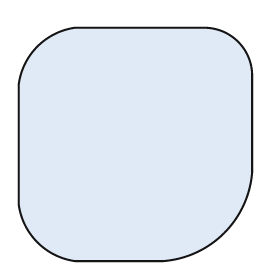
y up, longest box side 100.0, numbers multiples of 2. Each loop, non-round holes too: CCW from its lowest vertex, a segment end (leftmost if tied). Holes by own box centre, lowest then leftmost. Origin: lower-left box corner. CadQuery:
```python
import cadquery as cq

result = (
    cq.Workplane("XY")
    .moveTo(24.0, 0.0)
    .lineTo(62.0, 0.0)
    .threePointArc((88.0, 12.0), (100.0, 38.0))
    .lineTo(100.0, 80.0)
    .threePointArc((94.0, 94.0), (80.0, 100.0))
    .lineTo(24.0, 100.0)
    .threePointArc((8.0, 92.0), (0.0, 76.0))
    .lineTo(0.0, 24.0)
    .threePointArc((8.0, 8.0), (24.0, 0.0))
    .close()
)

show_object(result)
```